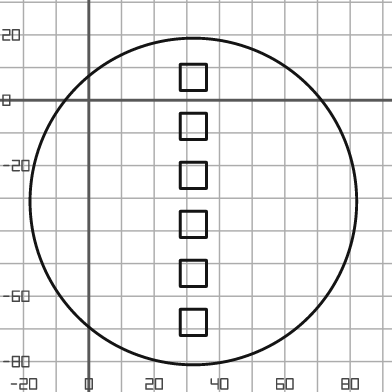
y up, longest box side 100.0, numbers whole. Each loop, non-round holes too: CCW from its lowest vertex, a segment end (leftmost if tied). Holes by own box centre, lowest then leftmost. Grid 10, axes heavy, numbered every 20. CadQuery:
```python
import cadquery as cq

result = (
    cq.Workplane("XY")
    .moveTo(32.0, -31.0)
    .circle(50.0)
    .moveTo(28.0, -72.0)
    .lineTo(36.0, -72.0)
    .lineTo(36.0, -64.0)
    .lineTo(28.0, -64.0)
    .close()
    .moveTo(28.0, -57.0)
    .lineTo(36.0, -57.0)
    .lineTo(36.0, -49.0)
    .lineTo(28.0, -49.0)
    .close()
    .moveTo(28.0, -42.0)
    .lineTo(36.0, -42.0)
    .lineTo(36.0, -34.0)
    .lineTo(28.0, -34.0)
    .close()
    .moveTo(28.0, -27.0)
    .lineTo(36.0, -27.0)
    .lineTo(36.0, -19.0)
    .lineTo(28.0, -19.0)
    .close()
    .moveTo(28.0, -12.0)
    .lineTo(36.0, -12.0)
    .lineTo(36.0, -4.0)
    .lineTo(28.0, -4.0)
    .close()
    .moveTo(28.0, 3.0)
    .lineTo(36.0, 3.0)
    .lineTo(36.0, 11.0)
    .lineTo(28.0, 11.0)
    .close()
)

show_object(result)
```